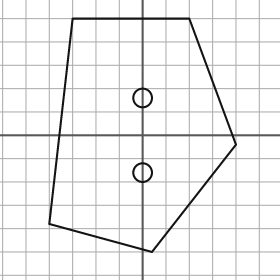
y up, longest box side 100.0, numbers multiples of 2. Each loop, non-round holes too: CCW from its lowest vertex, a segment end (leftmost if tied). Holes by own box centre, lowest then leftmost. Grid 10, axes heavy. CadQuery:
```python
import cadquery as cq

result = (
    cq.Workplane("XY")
    .moveTo(4.0, -50.0)
    .lineTo(40.0, -4.0)
    .lineTo(20.0, 50.0)
    .lineTo(-30.0, 50.0)
    .lineTo(-40.0, -38.0)
    .close()
    .moveTo(0.0, -16.0)
    .circle(4.0)
    .moveTo(0.0, 16.0)
    .circle(4.0)
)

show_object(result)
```